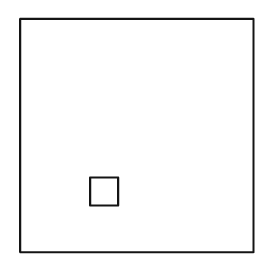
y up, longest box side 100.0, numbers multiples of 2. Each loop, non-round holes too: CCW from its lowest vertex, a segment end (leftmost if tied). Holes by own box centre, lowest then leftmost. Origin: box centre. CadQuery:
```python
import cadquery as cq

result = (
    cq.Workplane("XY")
    .moveTo(-50.0, -50.0)
    .lineTo(50.0, -50.0)
    .lineTo(50.0, 50.0)
    .lineTo(-50.0, 50.0)
    .close()
    .moveTo(-20.0, -30.0)
    .lineTo(-8.0, -30.0)
    .lineTo(-8.0, -18.0)
    .lineTo(-20.0, -18.0)
    .close()
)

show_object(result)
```